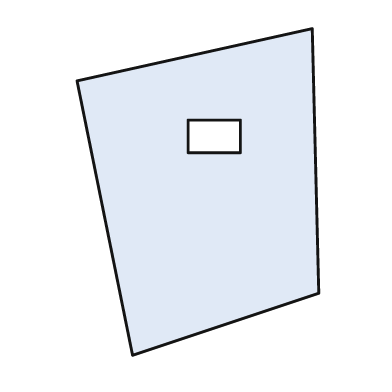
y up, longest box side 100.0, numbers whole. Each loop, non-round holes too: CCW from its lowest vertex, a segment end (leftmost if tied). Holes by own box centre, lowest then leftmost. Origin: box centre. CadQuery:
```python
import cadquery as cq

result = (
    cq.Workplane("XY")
    .moveTo(-20.0, -50.0)
    .lineTo(37.0, -31.0)
    .lineTo(35.0, 50.0)
    .lineTo(-37.0, 34.0)
    .close()
    .moveTo(-3.0, 12.0)
    .lineTo(13.0, 12.0)
    .lineTo(13.0, 22.0)
    .lineTo(-3.0, 22.0)
    .close()
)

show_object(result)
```